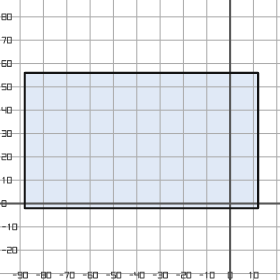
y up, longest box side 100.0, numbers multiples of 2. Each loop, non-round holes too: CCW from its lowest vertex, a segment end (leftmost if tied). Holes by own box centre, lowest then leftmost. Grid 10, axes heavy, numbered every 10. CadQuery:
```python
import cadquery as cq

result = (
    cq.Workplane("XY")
    .moveTo(-88.0, -2.0)
    .lineTo(12.0, -2.0)
    .lineTo(12.0, 56.0)
    .lineTo(-88.0, 56.0)
    .close()
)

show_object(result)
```